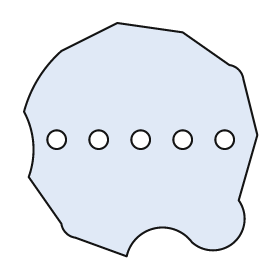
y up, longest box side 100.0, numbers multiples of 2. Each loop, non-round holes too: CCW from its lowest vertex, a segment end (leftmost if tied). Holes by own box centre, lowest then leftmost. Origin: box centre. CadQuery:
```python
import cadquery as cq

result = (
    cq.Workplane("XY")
    .moveTo(-6.0, -50.0)
    .threePointArc((6.0, -38.0), (22.0, -44.0))
    .threePointArc((40.0, -44.0), (42.0, -26.0))
    .lineTo(50.0, 2.0)
    .lineTo(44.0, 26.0)
    .threePointArc((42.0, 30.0), (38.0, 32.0))
    .lineTo(18.0, 46.0)
    .lineTo(-10.0, 50.0)
    .lineTo(-34.0, 38.0)
    .threePointArc((-44.0, 26.0), (-50.0, 12.0))
    .threePointArc((-46.0, -2.0), (-48.0, -16.0))
    .lineTo(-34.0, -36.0)
    .threePointArc((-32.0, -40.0), (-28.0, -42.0))
    .close()
    .moveTo(-36.0, 0.0)
    .circle(4.0)
    .moveTo(-18.0, 0.0)
    .circle(4.0)
    .moveTo(0.0, 0.0)
    .circle(4.0)
    .moveTo(18.0, 0.0)
    .circle(4.0)
    .moveTo(36.0, 0.0)
    .circle(4.0)
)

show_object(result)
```